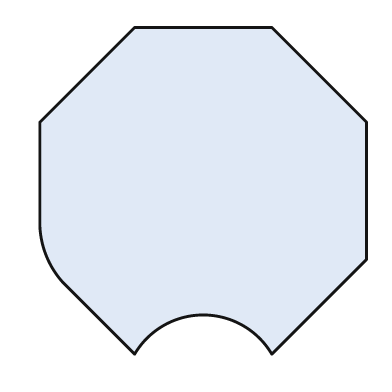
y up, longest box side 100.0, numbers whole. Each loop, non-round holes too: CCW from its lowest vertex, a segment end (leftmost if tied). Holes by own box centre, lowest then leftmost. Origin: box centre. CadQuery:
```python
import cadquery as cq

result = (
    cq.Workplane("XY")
    .moveTo(-21.0, -50.0)
    .threePointArc((0.0, -38.0), (21.0, -50.0))
    .lineTo(50.0, -21.0)
    .lineTo(50.0, 21.0)
    .lineTo(21.0, 50.0)
    .lineTo(-21.0, 50.0)
    .lineTo(-50.0, 21.0)
    .lineTo(-50.0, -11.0)
    .threePointArc((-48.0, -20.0), (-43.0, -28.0))
    .close()
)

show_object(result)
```